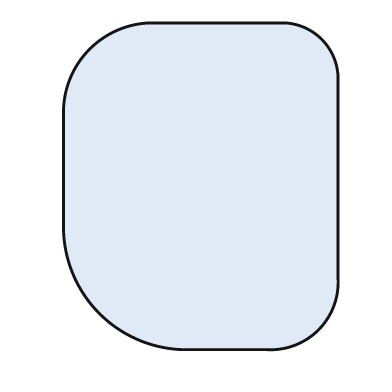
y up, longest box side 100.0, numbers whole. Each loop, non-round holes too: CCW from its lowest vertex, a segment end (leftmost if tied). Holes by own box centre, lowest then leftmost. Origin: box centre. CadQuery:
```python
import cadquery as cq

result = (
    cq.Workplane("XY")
    .moveTo(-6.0, -50.0)
    .lineTo(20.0, -50.0)
    .threePointArc((36.0, -44.0), (42.0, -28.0))
    .lineTo(42.0, 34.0)
    .threePointArc((37.0, 45.0), (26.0, 50.0))
    .lineTo(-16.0, 50.0)
    .threePointArc((-34.0, 42.0), (-42.0, 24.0))
    .lineTo(-42.0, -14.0)
    .threePointArc((-31.0, -39.0), (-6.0, -50.0))
    .close()
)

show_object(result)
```